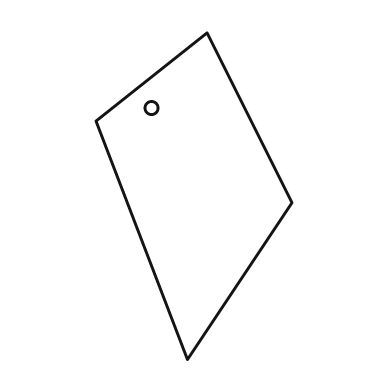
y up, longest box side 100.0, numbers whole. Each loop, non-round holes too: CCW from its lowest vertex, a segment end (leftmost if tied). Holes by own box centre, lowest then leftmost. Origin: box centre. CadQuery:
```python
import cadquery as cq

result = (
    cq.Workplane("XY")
    .moveTo(-2.0, -50.0)
    .lineTo(30.0, -2.0)
    .lineTo(4.0, 50.0)
    .lineTo(-30.0, 23.0)
    .close()
    .moveTo(-13.0, 27.0)
    .circle(2.0)
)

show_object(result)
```